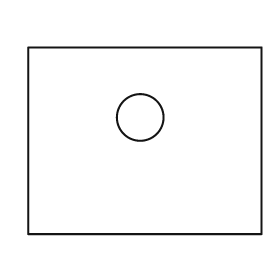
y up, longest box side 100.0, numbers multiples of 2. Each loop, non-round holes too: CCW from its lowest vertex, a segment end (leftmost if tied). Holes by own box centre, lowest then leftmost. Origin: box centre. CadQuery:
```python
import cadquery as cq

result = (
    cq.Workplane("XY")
    .moveTo(-50.0, -40.0)
    .lineTo(50.0, -40.0)
    .lineTo(50.0, 40.0)
    .lineTo(-50.0, 40.0)
    .close()
    .moveTo(-2.0, 10.0)
    .circle(10.0)
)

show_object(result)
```